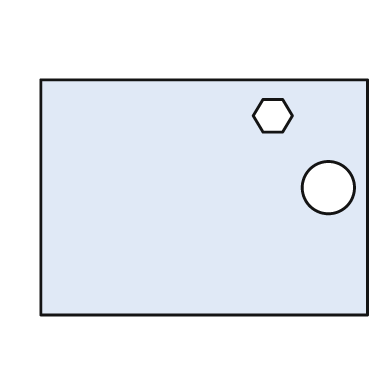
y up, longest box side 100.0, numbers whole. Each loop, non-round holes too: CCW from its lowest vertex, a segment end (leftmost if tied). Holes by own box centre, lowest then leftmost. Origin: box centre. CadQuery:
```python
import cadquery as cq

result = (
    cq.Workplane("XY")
    .moveTo(-50.0, -36.0)
    .lineTo(50.0, -36.0)
    .lineTo(50.0, 36.0)
    .lineTo(-50.0, 36.0)
    .close()
    .moveTo(38.0, 3.0)
    .circle(8.0)
    .moveTo(18.0, 20.0)
    .lineTo(24.0, 20.0)
    .lineTo(27.0, 25.0)
    .lineTo(24.0, 30.0)
    .lineTo(18.0, 30.0)
    .lineTo(15.0, 25.0)
    .close()
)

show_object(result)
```